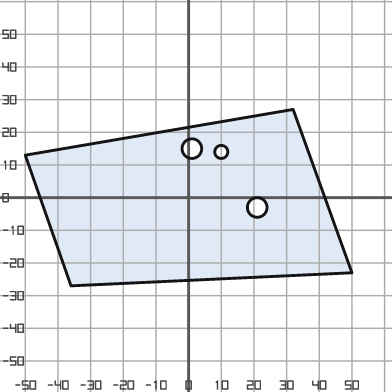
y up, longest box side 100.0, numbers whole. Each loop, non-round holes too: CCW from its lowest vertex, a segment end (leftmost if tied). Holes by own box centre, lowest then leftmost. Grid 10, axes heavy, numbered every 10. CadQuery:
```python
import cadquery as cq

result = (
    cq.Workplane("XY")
    .moveTo(-36.0, -27.0)
    .lineTo(50.0, -23.0)
    .lineTo(32.0, 27.0)
    .lineTo(-50.0, 13.0)
    .close()
    .moveTo(21.0, -3.0)
    .circle(3.0)
    .moveTo(10.0, 14.0)
    .circle(2.0)
    .moveTo(1.0, 15.0)
    .circle(3.0)
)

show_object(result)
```